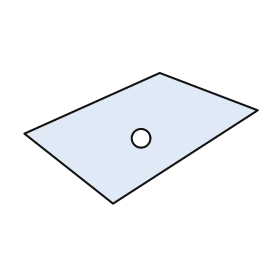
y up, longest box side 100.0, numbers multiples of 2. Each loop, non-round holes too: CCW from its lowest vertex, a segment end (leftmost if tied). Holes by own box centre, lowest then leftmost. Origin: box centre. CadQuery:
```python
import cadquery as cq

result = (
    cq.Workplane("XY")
    .moveTo(-12.0, -28.0)
    .lineTo(50.0, 12.0)
    .lineTo(8.0, 28.0)
    .lineTo(-50.0, 2.0)
    .close()
    .moveTo(0.0, 0.0)
    .circle(4.0)
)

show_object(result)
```